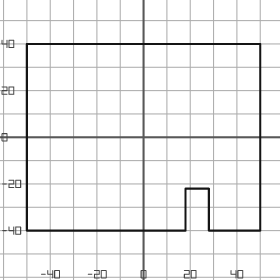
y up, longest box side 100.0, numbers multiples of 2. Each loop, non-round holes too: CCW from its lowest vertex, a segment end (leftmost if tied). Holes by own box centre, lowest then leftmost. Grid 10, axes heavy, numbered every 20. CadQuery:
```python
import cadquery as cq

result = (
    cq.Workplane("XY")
    .moveTo(-50.0, -40.0)
    .lineTo(18.0, -40.0)
    .lineTo(18.0, -22.0)
    .lineTo(28.0, -22.0)
    .lineTo(28.0, -40.0)
    .lineTo(50.0, -40.0)
    .lineTo(50.0, 40.0)
    .lineTo(-50.0, 40.0)
    .close()
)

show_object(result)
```